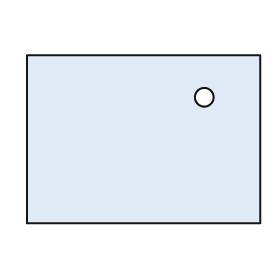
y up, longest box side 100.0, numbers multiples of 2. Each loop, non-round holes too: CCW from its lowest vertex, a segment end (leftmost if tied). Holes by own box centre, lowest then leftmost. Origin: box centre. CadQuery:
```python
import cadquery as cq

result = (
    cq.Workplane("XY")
    .moveTo(-50.0, -36.0)
    .lineTo(50.0, -36.0)
    .lineTo(50.0, 36.0)
    .lineTo(-50.0, 36.0)
    .close()
    .moveTo(26.0, 18.0)
    .circle(4.0)
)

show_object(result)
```